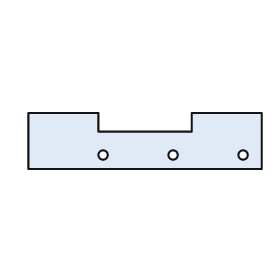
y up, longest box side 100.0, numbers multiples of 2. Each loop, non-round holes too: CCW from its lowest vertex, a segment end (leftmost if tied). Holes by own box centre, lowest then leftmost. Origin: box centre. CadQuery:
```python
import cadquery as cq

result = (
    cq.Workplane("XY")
    .moveTo(-50.0, -12.0)
    .lineTo(50.0, -12.0)
    .lineTo(50.0, 12.0)
    .lineTo(20.0, 12.0)
    .lineTo(20.0, 4.0)
    .lineTo(-20.0, 4.0)
    .lineTo(-20.0, 12.0)
    .lineTo(-50.0, 12.0)
    .close()
    .moveTo(-18.0, -6.0)
    .circle(2.0)
    .moveTo(12.0, -6.0)
    .circle(2.0)
    .moveTo(42.0, -6.0)
    .circle(2.0)
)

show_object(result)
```